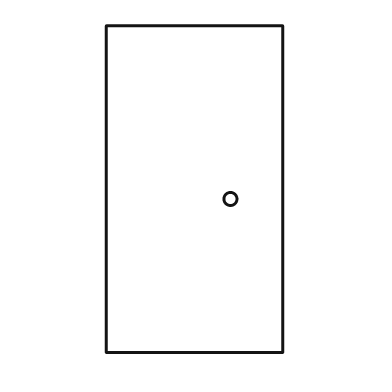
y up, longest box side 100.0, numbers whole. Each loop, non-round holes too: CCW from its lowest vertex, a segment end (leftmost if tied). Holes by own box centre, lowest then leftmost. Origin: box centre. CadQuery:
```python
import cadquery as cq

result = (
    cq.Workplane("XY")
    .moveTo(-27.0, -50.0)
    .lineTo(27.0, -50.0)
    .lineTo(27.0, 50.0)
    .lineTo(-27.0, 50.0)
    .close()
    .moveTo(11.0, -3.0)
    .circle(2.0)
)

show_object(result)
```